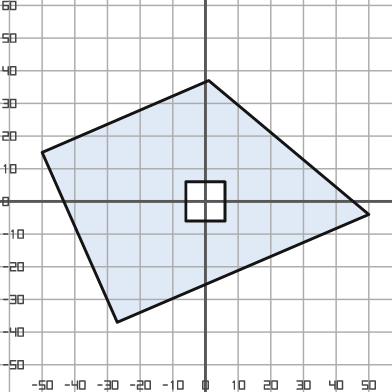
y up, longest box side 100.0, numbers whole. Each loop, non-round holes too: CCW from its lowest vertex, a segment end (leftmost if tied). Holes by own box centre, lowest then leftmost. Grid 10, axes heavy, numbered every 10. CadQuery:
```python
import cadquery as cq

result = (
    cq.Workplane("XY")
    .moveTo(-27.0, -37.0)
    .lineTo(50.0, -4.0)
    .lineTo(1.0, 37.0)
    .lineTo(-50.0, 15.0)
    .close()
    .moveTo(-6.0, -6.0)
    .lineTo(6.0, -6.0)
    .lineTo(6.0, 6.0)
    .lineTo(-6.0, 6.0)
    .close()
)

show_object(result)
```